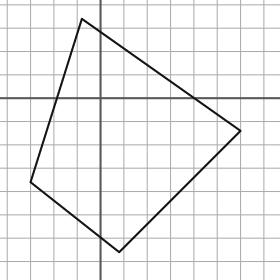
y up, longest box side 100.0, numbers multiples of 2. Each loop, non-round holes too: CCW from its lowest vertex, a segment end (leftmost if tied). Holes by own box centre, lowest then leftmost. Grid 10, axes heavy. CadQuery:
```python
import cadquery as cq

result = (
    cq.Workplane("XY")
    .moveTo(8.0, -66.0)
    .lineTo(60.0, -14.0)
    .lineTo(-8.0, 34.0)
    .lineTo(-30.0, -36.0)
    .close()
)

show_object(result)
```